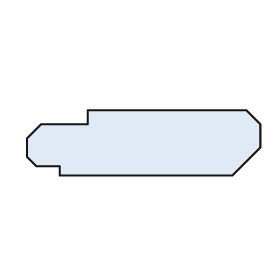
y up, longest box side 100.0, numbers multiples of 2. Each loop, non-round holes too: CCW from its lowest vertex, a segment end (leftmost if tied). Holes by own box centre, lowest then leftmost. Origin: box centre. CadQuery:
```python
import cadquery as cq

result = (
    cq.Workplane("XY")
    .moveTo(-36.0, -14.0)
    .lineTo(38.0, -14.0)
    .lineTo(50.0, -2.0)
    .lineTo(50.0, 8.0)
    .lineTo(44.0, 14.0)
    .lineTo(-24.0, 14.0)
    .lineTo(-24.0, 8.0)
    .lineTo(-44.0, 8.0)
    .lineTo(-50.0, 2.0)
    .lineTo(-50.0, -6.0)
    .lineTo(-46.0, -10.0)
    .lineTo(-36.0, -10.0)
    .close()
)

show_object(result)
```